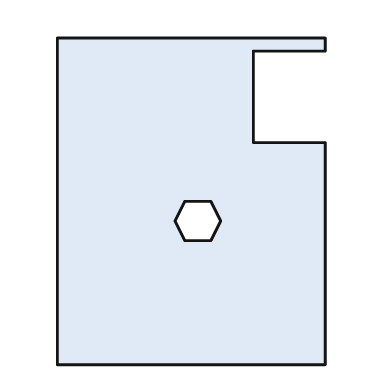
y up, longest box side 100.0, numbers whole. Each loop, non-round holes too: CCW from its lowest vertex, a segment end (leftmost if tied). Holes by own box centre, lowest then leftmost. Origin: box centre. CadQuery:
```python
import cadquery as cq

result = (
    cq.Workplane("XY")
    .moveTo(-41.0, -50.0)
    .lineTo(41.0, -50.0)
    .lineTo(41.0, 18.0)
    .lineTo(19.0, 18.0)
    .lineTo(19.0, 46.0)
    .lineTo(41.0, 46.0)
    .lineTo(41.0, 50.0)
    .lineTo(-41.0, 50.0)
    .close()
    .moveTo(-2.0, -12.0)
    .lineTo(6.0, -12.0)
    .lineTo(9.0, -6.0)
    .lineTo(6.0, 0.0)
    .lineTo(-2.0, 0.0)
    .lineTo(-5.0, -6.0)
    .close()
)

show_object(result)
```